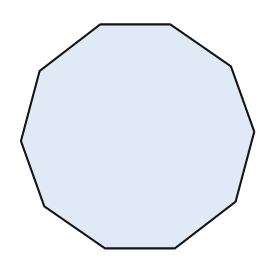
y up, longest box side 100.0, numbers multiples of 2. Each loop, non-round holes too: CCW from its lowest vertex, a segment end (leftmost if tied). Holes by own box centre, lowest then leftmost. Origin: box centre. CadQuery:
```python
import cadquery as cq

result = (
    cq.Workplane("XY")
    .moveTo(-14.0, -48.0)
    .lineTo(16.0, -48.0)
    .lineTo(42.0, -28.0)
    .lineTo(50.0, 2.0)
    .lineTo(40.0, 30.0)
    .lineTo(14.0, 48.0)
    .lineTo(-16.0, 48.0)
    .lineTo(-42.0, 28.0)
    .lineTo(-50.0, -2.0)
    .lineTo(-40.0, -30.0)
    .close()
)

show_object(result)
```